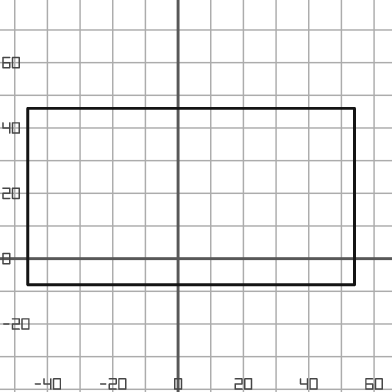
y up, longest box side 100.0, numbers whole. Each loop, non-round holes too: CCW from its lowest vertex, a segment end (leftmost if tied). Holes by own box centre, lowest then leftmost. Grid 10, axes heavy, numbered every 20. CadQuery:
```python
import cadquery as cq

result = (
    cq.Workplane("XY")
    .moveTo(-46.0, -8.0)
    .lineTo(54.0, -8.0)
    .lineTo(54.0, 46.0)
    .lineTo(-46.0, 46.0)
    .close()
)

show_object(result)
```